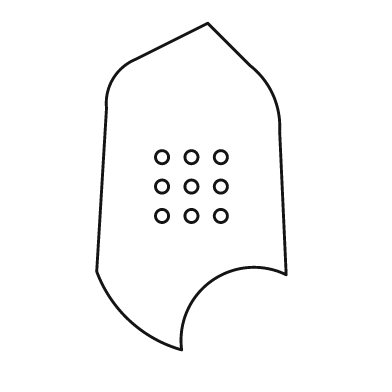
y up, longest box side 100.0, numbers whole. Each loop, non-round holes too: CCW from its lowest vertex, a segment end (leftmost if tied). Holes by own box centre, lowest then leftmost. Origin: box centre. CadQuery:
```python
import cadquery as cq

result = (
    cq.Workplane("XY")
    .moveTo(-3.0, -50.0)
    .threePointArc((6.0, -29.0), (29.0, -27.0))
    .lineTo(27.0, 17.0)
    .threePointArc((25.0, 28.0), (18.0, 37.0))
    .lineTo(5.0, 50.0)
    .lineTo(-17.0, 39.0)
    .threePointArc((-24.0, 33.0), (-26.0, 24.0))
    .lineTo(-29.0, -26.0)
    .threePointArc((-19.0, -41.0), (-3.0, -50.0))
    .close()
    .moveTo(-9.0, -9.0)
    .circle(2.0)
    .moveTo(0.0, -9.0)
    .circle(2.0)
    .moveTo(9.0, -9.0)
    .circle(2.0)
    .moveTo(-9.0, 0.0)
    .circle(2.0)
    .moveTo(0.0, 0.0)
    .circle(2.0)
    .moveTo(9.0, 0.0)
    .circle(2.0)
    .moveTo(-9.0, 9.0)
    .circle(2.0)
    .moveTo(0.0, 9.0)
    .circle(2.0)
    .moveTo(9.0, 9.0)
    .circle(2.0)
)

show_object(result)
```